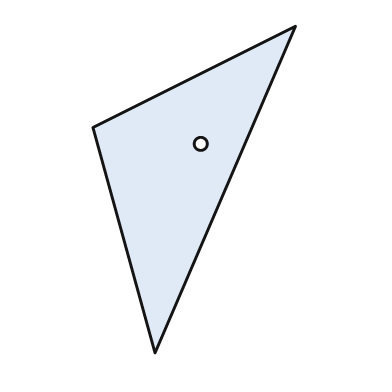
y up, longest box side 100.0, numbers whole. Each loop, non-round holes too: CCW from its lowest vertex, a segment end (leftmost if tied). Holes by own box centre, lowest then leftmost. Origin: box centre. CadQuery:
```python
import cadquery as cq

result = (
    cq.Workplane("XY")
    .moveTo(-12.0, -50.0)
    .lineTo(31.0, 50.0)
    .lineTo(-31.0, 19.0)
    .close()
    .moveTo(2.0, 14.0)
    .circle(2.0)
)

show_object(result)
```